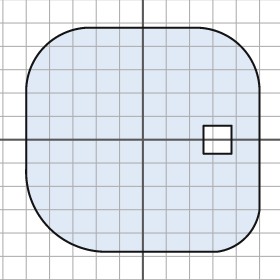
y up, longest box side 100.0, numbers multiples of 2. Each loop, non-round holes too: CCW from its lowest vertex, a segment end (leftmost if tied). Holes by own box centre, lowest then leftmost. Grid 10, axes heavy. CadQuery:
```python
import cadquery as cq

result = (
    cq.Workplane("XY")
    .moveTo(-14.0, -48.0)
    .lineTo(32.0, -48.0)
    .threePointArc((44.0, -42.0), (50.0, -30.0))
    .lineTo(50.0, 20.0)
    .threePointArc((42.0, 40.0), (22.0, 48.0))
    .lineTo(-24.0, 48.0)
    .threePointArc((-42.0, 40.0), (-50.0, 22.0))
    .lineTo(-50.0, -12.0)
    .threePointArc((-40.0, -38.0), (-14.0, -48.0))
    .close()
    .moveTo(26.0, -6.0)
    .lineTo(38.0, -6.0)
    .lineTo(38.0, 6.0)
    .lineTo(26.0, 6.0)
    .close()
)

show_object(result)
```